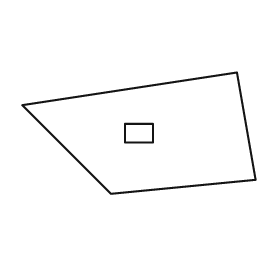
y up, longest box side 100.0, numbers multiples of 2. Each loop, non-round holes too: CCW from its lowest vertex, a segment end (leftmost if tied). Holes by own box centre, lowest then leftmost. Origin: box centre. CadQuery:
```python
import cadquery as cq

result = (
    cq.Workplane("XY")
    .moveTo(-12.0, -26.0)
    .lineTo(50.0, -20.0)
    .lineTo(42.0, 26.0)
    .lineTo(-50.0, 12.0)
    .close()
    .moveTo(-6.0, -4.0)
    .lineTo(6.0, -4.0)
    .lineTo(6.0, 4.0)
    .lineTo(-6.0, 4.0)
    .close()
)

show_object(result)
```